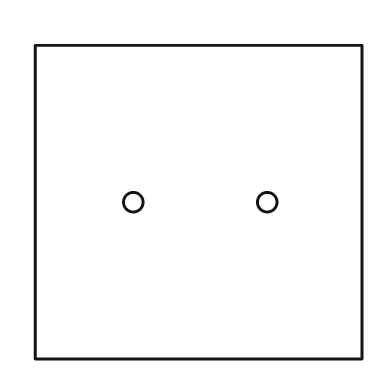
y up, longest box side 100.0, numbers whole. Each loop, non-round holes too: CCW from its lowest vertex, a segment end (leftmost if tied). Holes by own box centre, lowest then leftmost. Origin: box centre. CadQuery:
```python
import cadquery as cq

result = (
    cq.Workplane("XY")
    .moveTo(-50.0, -48.0)
    .lineTo(50.0, -48.0)
    .lineTo(50.0, 48.0)
    .lineTo(-50.0, 48.0)
    .close()
    .moveTo(-20.0, 0.0)
    .circle(3.0)
    .moveTo(21.0, 0.0)
    .circle(3.0)
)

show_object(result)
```